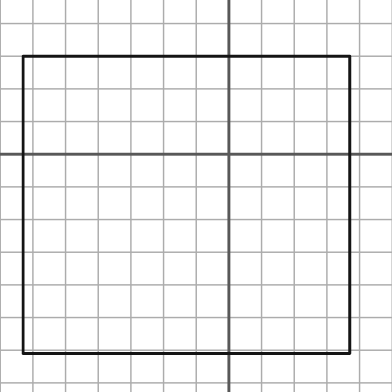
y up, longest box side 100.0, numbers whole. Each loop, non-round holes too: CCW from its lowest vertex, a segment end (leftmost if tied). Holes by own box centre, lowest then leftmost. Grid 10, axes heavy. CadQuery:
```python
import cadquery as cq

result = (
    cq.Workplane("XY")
    .moveTo(-63.0, -61.0)
    .lineTo(37.0, -61.0)
    .lineTo(37.0, 30.0)
    .lineTo(-63.0, 30.0)
    .close()
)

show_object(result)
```